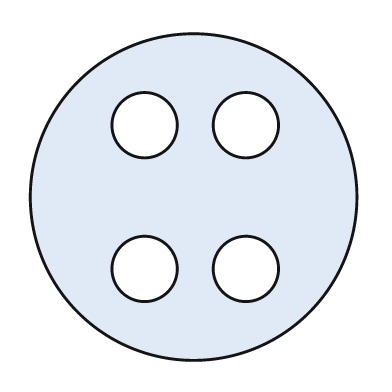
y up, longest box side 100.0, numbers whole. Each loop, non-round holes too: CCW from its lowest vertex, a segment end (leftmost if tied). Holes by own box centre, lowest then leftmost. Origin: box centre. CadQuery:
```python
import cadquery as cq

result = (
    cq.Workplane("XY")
    .moveTo(0.0, 0.0)
    .circle(50.0)
    .moveTo(-15.0, -22.0)
    .circle(10.0)
    .moveTo(16.0, -22.0)
    .circle(10.0)
    .moveTo(-15.0, 22.0)
    .circle(10.0)
    .moveTo(16.0, 22.0)
    .circle(10.0)
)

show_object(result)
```